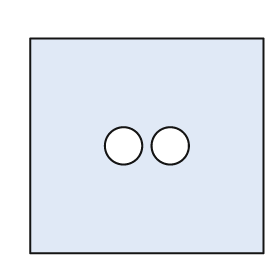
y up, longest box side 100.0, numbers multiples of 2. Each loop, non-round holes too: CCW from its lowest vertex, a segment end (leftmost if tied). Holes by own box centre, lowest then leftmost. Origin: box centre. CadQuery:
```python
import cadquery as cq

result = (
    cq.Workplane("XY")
    .moveTo(-50.0, -46.0)
    .lineTo(50.0, -46.0)
    .lineTo(50.0, 46.0)
    .lineTo(-50.0, 46.0)
    .close()
    .moveTo(-10.0, 0.0)
    .circle(8.0)
    .moveTo(10.0, 0.0)
    .circle(8.0)
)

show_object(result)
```